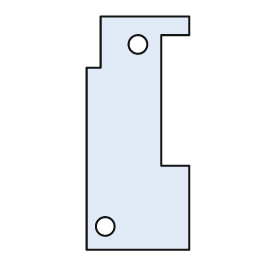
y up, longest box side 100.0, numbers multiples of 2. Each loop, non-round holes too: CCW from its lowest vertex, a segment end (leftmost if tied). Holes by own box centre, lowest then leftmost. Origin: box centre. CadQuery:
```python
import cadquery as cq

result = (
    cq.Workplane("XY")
    .moveTo(-22.0, -50.0)
    .lineTo(22.0, -50.0)
    .lineTo(22.0, -14.0)
    .lineTo(10.0, -14.0)
    .lineTo(10.0, 42.0)
    .lineTo(22.0, 42.0)
    .lineTo(22.0, 50.0)
    .lineTo(-16.0, 50.0)
    .lineTo(-16.0, 28.0)
    .lineTo(-22.0, 28.0)
    .close()
    .moveTo(-14.0, -40.0)
    .circle(4.0)
    .moveTo(0.0, 38.0)
    .circle(4.0)
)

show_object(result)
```